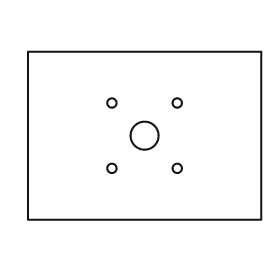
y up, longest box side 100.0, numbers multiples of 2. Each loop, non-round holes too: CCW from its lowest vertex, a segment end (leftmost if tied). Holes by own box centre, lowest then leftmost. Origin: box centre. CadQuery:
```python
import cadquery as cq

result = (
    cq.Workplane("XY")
    .moveTo(-50.0, -36.0)
    .lineTo(50.0, -36.0)
    .lineTo(50.0, 36.0)
    .lineTo(-50.0, 36.0)
    .close()
    .moveTo(-14.0, -14.0)
    .circle(2.0)
    .moveTo(14.0, -14.0)
    .circle(2.0)
    .moveTo(0.0, 0.0)
    .circle(6.0)
    .moveTo(-14.0, 14.0)
    .circle(2.0)
    .moveTo(14.0, 14.0)
    .circle(2.0)
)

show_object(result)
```